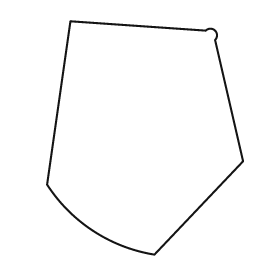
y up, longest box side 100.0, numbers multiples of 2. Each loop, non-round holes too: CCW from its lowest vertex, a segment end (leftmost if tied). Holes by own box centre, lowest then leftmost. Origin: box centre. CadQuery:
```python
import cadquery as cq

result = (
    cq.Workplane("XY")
    .moveTo(4.0, -50.0)
    .lineTo(42.0, -10.0)
    .lineTo(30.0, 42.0)
    .threePointArc((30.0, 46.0), (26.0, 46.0))
    .lineTo(-32.0, 50.0)
    .lineTo(-42.0, -20.0)
    .threePointArc((-22.0, -40.0), (4.0, -50.0))
    .close()
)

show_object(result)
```